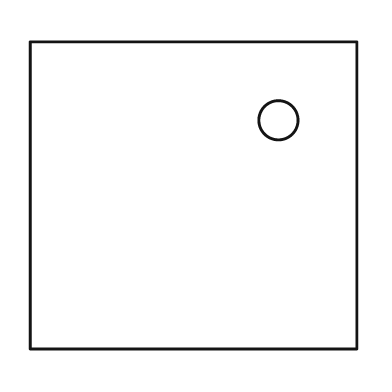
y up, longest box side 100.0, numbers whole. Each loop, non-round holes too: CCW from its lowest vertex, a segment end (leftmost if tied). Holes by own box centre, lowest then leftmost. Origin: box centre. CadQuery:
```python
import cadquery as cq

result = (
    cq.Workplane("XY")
    .moveTo(-50.0, -47.0)
    .lineTo(50.0, -47.0)
    .lineTo(50.0, 47.0)
    .lineTo(-50.0, 47.0)
    .close()
    .moveTo(26.0, 23.0)
    .circle(6.0)
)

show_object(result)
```